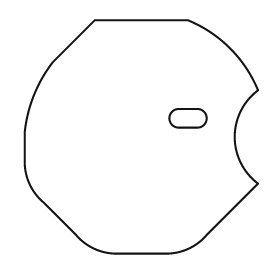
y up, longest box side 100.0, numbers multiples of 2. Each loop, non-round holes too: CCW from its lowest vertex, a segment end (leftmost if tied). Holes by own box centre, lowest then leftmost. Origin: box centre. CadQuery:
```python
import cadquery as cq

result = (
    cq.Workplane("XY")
    .moveTo(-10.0, -50.0)
    .lineTo(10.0, -50.0)
    .threePointArc((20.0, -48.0), (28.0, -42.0))
    .lineTo(50.0, -20.0)
    .threePointArc((40.0, 0.0), (50.0, 20.0))
    .threePointArc((38.0, 38.0), (20.0, 50.0))
    .lineTo(-20.0, 50.0)
    .lineTo(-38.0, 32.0)
    .threePointArc((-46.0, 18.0), (-50.0, 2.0))
    .lineTo(-50.0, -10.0)
    .threePointArc((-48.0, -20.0), (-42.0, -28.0))
    .lineTo(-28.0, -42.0)
    .threePointArc((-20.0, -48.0), (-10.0, -50.0))
    .close()
    .moveTo(16.0, 4.0)
    .lineTo(24.0, 4.0)
    .threePointArc((28.0, 8.0), (24.0, 12.0))
    .lineTo(16.0, 12.0)
    .threePointArc((12.0, 8.0), (16.0, 4.0))
    .close()
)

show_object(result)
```